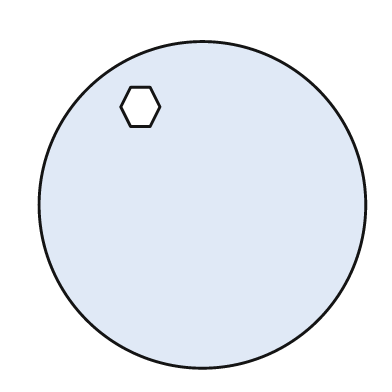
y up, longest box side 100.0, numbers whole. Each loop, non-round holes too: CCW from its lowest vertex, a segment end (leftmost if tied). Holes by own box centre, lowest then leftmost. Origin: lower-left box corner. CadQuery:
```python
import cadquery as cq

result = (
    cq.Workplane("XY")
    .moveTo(50.0, 50.0)
    .circle(50.0)
    .moveTo(28.0, 74.0)
    .lineTo(34.0, 74.0)
    .lineTo(37.0, 80.0)
    .lineTo(34.0, 86.0)
    .lineTo(28.0, 86.0)
    .lineTo(25.0, 80.0)
    .close()
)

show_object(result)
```